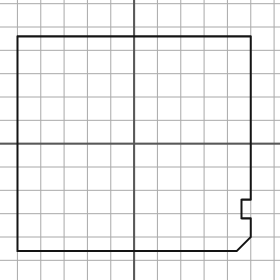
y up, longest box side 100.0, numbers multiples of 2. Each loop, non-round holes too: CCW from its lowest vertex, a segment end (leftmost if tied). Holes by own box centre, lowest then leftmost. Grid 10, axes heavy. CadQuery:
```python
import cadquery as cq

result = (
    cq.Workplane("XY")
    .moveTo(-50.0, -46.0)
    .lineTo(44.0, -46.0)
    .lineTo(50.0, -40.0)
    .lineTo(50.0, -32.0)
    .lineTo(46.0, -32.0)
    .lineTo(46.0, -24.0)
    .lineTo(50.0, -24.0)
    .lineTo(50.0, 46.0)
    .lineTo(-50.0, 46.0)
    .close()
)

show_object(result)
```